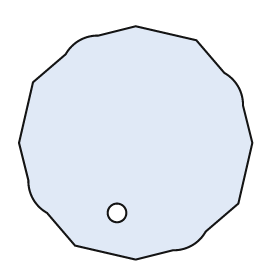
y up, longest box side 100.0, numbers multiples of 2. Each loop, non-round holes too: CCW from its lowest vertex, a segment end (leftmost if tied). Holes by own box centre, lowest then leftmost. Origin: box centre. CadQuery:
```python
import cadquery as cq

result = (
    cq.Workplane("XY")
    .moveTo(0.0, -50.0)
    .lineTo(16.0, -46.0)
    .threePointArc((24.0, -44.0), (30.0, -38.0))
    .lineTo(44.0, -26.0)
    .lineTo(50.0, 0.0)
    .lineTo(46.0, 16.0)
    .threePointArc((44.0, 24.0), (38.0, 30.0))
    .lineTo(26.0, 44.0)
    .lineTo(0.0, 50.0)
    .lineTo(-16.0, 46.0)
    .threePointArc((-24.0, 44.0), (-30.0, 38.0))
    .lineTo(-44.0, 26.0)
    .lineTo(-50.0, 0.0)
    .lineTo(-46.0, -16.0)
    .threePointArc((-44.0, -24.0), (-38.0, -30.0))
    .lineTo(-26.0, -44.0)
    .close()
    .moveTo(-8.0, -30.0)
    .circle(4.0)
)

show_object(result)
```